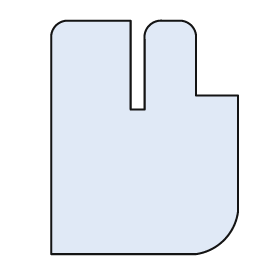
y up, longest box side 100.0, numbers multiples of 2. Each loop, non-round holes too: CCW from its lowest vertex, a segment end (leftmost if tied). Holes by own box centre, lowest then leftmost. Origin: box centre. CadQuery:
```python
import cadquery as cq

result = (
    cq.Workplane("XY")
    .moveTo(-40.0, -50.0)
    .lineTo(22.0, -50.0)
    .threePointArc((34.0, -44.0), (40.0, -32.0))
    .lineTo(40.0, 18.0)
    .lineTo(22.0, 18.0)
    .lineTo(22.0, 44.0)
    .threePointArc((20.0, 48.0), (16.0, 50.0))
    .lineTo(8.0, 50.0)
    .threePointArc((2.0, 48.0), (0.0, 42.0))
    .lineTo(0.0, 12.0)
    .lineTo(-6.0, 12.0)
    .lineTo(-6.0, 50.0)
    .lineTo(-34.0, 50.0)
    .threePointArc((-38.0, 48.0), (-40.0, 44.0))
    .close()
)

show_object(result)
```